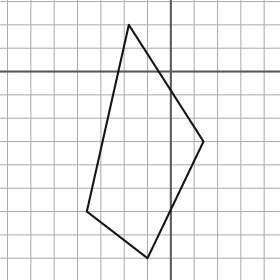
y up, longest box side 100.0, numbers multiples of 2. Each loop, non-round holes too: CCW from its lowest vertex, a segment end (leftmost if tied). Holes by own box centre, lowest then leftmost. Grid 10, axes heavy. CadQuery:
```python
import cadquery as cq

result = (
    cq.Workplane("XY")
    .moveTo(-10.0, -80.0)
    .lineTo(14.0, -30.0)
    .lineTo(-18.0, 20.0)
    .lineTo(-36.0, -60.0)
    .close()
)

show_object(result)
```